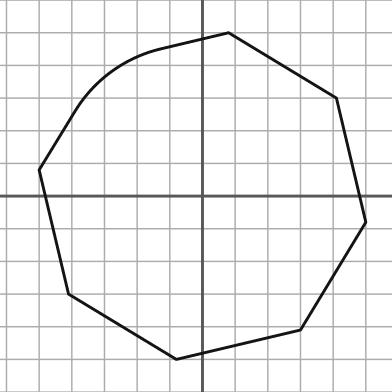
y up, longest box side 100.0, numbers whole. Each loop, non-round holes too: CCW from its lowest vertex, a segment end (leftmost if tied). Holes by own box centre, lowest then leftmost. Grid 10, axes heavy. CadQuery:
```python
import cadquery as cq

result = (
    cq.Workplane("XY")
    .moveTo(-8.0, -50.0)
    .lineTo(30.0, -41.0)
    .lineTo(50.0, -8.0)
    .lineTo(41.0, 30.0)
    .lineTo(8.0, 50.0)
    .lineTo(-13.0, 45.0)
    .threePointArc((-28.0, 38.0), (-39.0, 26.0))
    .lineTo(-50.0, 8.0)
    .lineTo(-41.0, -30.0)
    .close()
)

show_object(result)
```